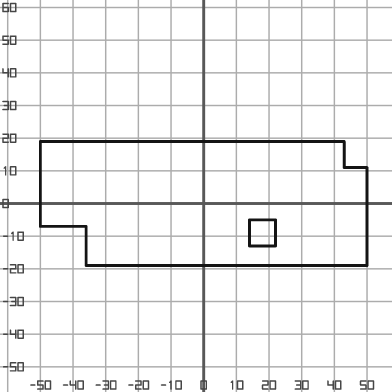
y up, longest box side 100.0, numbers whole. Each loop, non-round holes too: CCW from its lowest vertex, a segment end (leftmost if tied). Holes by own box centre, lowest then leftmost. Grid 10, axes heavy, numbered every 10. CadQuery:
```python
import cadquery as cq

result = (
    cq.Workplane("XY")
    .moveTo(-36.0, -19.0)
    .lineTo(50.0, -19.0)
    .lineTo(50.0, 11.0)
    .lineTo(43.0, 11.0)
    .lineTo(43.0, 19.0)
    .lineTo(-50.0, 19.0)
    .lineTo(-50.0, -7.0)
    .lineTo(-36.0, -7.0)
    .close()
    .moveTo(14.0, -13.0)
    .lineTo(22.0, -13.0)
    .lineTo(22.0, -5.0)
    .lineTo(14.0, -5.0)
    .close()
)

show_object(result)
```